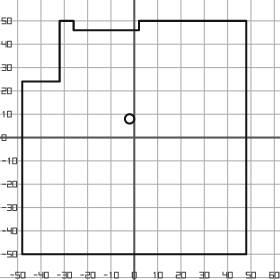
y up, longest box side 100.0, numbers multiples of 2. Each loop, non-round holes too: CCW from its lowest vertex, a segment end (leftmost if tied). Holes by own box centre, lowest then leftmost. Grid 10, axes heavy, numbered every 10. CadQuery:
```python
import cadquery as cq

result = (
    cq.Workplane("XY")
    .moveTo(-48.0, -50.0)
    .lineTo(48.0, -50.0)
    .lineTo(48.0, 50.0)
    .lineTo(2.0, 50.0)
    .lineTo(2.0, 46.0)
    .lineTo(-26.0, 46.0)
    .lineTo(-26.0, 50.0)
    .lineTo(-32.0, 50.0)
    .lineTo(-32.0, 24.0)
    .lineTo(-48.0, 24.0)
    .close()
    .moveTo(-2.0, 8.0)
    .circle(2.0)
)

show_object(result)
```